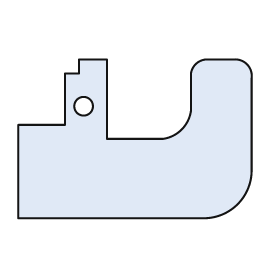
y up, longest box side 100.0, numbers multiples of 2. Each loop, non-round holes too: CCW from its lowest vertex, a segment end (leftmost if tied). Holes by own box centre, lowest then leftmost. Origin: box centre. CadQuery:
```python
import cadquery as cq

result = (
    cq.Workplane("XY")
    .moveTo(-50.0, -34.0)
    .lineTo(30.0, -34.0)
    .threePointArc((44.0, -28.0), (50.0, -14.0))
    .lineTo(50.0, 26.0)
    .threePointArc((48.0, 32.0), (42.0, 34.0))
    .lineTo(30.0, 34.0)
    .threePointArc((26.0, 32.0), (24.0, 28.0))
    .lineTo(24.0, 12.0)
    .threePointArc((20.0, 4.0), (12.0, 0.0))
    .lineTo(-12.0, 0.0)
    .lineTo(-12.0, 34.0)
    .lineTo(-24.0, 34.0)
    .lineTo(-24.0, 28.0)
    .lineTo(-30.0, 28.0)
    .lineTo(-30.0, 6.0)
    .lineTo(-50.0, 6.0)
    .close()
    .moveTo(-22.0, 14.0)
    .circle(4.0)
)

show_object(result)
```